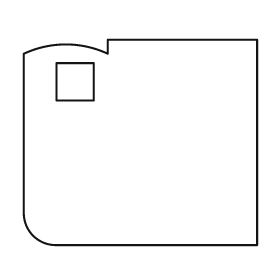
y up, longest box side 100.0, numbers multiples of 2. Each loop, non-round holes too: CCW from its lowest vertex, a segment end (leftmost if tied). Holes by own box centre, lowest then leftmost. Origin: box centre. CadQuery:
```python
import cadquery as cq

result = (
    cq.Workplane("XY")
    .moveTo(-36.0, -44.0)
    .lineTo(50.0, -44.0)
    .lineTo(50.0, 44.0)
    .lineTo(-14.0, 44.0)
    .lineTo(-14.0, 38.0)
    .threePointArc((-32.0, 42.0), (-50.0, 38.0))
    .lineTo(-50.0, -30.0)
    .threePointArc((-46.0, -40.0), (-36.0, -44.0))
    .close()
    .moveTo(-36.0, 18.0)
    .lineTo(-20.0, 18.0)
    .lineTo(-20.0, 34.0)
    .lineTo(-36.0, 34.0)
    .close()
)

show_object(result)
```